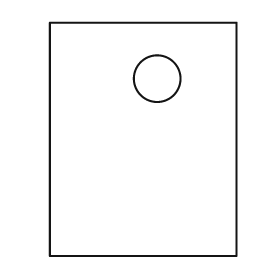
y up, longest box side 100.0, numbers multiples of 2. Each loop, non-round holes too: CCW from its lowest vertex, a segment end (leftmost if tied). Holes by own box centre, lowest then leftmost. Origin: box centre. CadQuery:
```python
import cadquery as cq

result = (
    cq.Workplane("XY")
    .moveTo(-40.0, -50.0)
    .lineTo(40.0, -50.0)
    .lineTo(40.0, 50.0)
    .lineTo(-40.0, 50.0)
    .close()
    .moveTo(6.0, 26.0)
    .circle(10.0)
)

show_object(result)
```